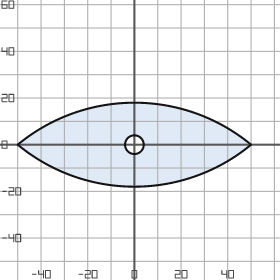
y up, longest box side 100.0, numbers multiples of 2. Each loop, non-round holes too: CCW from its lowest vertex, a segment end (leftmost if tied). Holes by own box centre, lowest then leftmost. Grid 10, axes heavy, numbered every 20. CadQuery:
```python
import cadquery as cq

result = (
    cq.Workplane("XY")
    .moveTo(-50.0, 0.0)
    .threePointArc((0.0, -18.0), (50.0, 0.0))
    .threePointArc((0.0, 18.0), (-50.0, 0.0))
    .close()
    .moveTo(0.0, 0.0)
    .circle(4.0)
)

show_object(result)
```